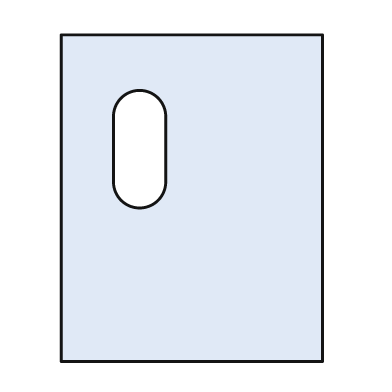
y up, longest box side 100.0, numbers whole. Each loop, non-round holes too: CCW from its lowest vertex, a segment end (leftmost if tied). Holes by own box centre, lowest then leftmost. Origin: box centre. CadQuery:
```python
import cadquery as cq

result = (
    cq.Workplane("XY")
    .moveTo(-40.0, -50.0)
    .lineTo(40.0, -50.0)
    .lineTo(40.0, 50.0)
    .lineTo(-40.0, 50.0)
    .close()
    .moveTo(-24.0, 5.0)
    .threePointArc((-16.0, -3.0), (-8.0, 5.0))
    .lineTo(-8.0, 25.0)
    .threePointArc((-16.0, 33.0), (-24.0, 25.0))
    .close()
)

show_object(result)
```